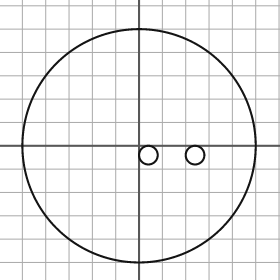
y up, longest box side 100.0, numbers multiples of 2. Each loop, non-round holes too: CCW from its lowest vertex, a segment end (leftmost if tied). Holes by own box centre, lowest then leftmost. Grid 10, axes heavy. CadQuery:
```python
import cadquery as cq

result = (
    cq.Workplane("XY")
    .moveTo(0.0, 0.0)
    .circle(50.0)
    .moveTo(4.0, -4.0)
    .circle(4.0)
    .moveTo(24.0, -4.0)
    .circle(4.0)
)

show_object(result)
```